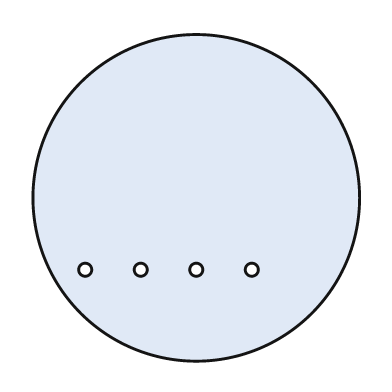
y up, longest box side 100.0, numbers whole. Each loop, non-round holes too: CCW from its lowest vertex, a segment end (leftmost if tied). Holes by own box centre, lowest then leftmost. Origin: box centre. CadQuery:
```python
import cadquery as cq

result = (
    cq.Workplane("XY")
    .moveTo(0.0, 0.0)
    .circle(50.0)
    .moveTo(-34.0, -22.0)
    .circle(2.0)
    .moveTo(-17.0, -22.0)
    .circle(2.0)
    .moveTo(0.0, -22.0)
    .circle(2.0)
    .moveTo(17.0, -22.0)
    .circle(2.0)
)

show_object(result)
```